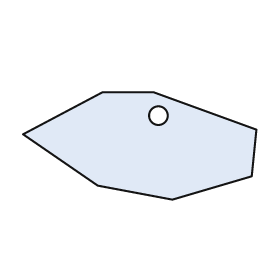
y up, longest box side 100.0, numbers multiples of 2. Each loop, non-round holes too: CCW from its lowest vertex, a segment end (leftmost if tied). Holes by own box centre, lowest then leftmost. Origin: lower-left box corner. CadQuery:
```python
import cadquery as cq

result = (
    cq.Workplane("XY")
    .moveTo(64.0, 0.0)
    .lineTo(98.0, 10.0)
    .lineTo(100.0, 30.0)
    .lineTo(56.0, 46.0)
    .lineTo(34.0, 46.0)
    .lineTo(0.0, 28.0)
    .lineTo(32.0, 6.0)
    .close()
    .moveTo(58.0, 36.0)
    .circle(4.0)
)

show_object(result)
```